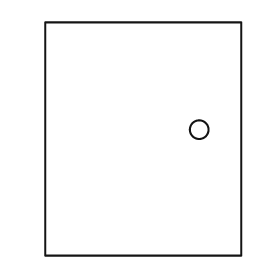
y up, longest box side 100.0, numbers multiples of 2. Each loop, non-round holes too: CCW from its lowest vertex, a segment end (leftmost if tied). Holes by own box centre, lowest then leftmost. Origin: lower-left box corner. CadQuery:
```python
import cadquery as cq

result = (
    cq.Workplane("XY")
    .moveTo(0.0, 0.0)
    .lineTo(84.0, 0.0)
    .lineTo(84.0, 100.0)
    .lineTo(0.0, 100.0)
    .close()
    .moveTo(66.0, 54.0)
    .circle(4.0)
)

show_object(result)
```